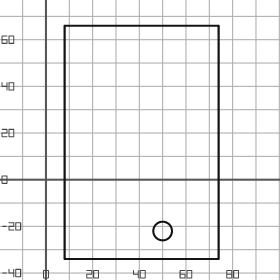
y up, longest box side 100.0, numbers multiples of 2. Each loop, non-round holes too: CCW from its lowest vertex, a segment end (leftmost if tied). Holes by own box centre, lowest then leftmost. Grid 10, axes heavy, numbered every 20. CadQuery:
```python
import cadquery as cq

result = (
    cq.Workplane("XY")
    .moveTo(8.0, -34.0)
    .lineTo(74.0, -34.0)
    .lineTo(74.0, 66.0)
    .lineTo(8.0, 66.0)
    .close()
    .moveTo(50.0, -22.0)
    .circle(4.0)
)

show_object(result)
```